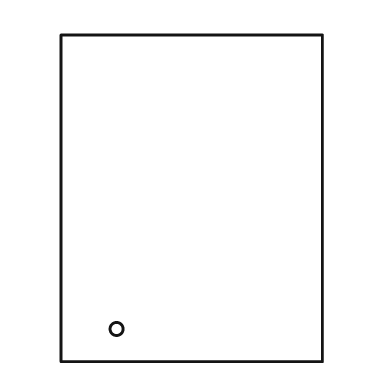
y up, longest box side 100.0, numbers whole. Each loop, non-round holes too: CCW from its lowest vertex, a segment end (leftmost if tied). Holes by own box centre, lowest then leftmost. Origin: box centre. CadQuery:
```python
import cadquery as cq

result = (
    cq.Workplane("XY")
    .moveTo(-40.0, -50.0)
    .lineTo(40.0, -50.0)
    .lineTo(40.0, 50.0)
    .lineTo(-40.0, 50.0)
    .close()
    .moveTo(-23.0, -40.0)
    .circle(2.0)
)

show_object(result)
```